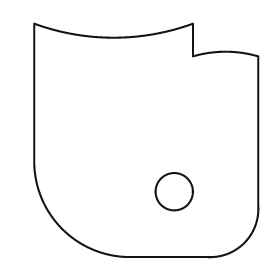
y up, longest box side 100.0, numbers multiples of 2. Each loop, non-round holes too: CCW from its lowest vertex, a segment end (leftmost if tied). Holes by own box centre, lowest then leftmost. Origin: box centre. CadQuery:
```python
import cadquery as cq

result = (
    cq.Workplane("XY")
    .moveTo(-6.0, -50.0)
    .lineTo(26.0, -50.0)
    .threePointArc((42.0, -44.0), (48.0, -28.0))
    .lineTo(48.0, 36.0)
    .threePointArc((34.0, 38.0), (20.0, 36.0))
    .lineTo(20.0, 50.0)
    .threePointArc((-14.0, 44.0), (-48.0, 50.0))
    .lineTo(-48.0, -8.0)
    .threePointArc((-36.0, -38.0), (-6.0, -50.0))
    .close()
    .moveTo(12.0, -22.0)
    .circle(8.0)
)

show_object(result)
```